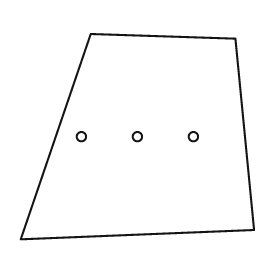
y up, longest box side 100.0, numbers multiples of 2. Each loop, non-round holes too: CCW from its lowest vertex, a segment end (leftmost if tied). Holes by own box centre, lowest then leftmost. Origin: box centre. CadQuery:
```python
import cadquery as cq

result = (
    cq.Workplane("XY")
    .moveTo(-50.0, -44.0)
    .lineTo(50.0, -40.0)
    .lineTo(42.0, 42.0)
    .lineTo(-20.0, 44.0)
    .close()
    .moveTo(-24.0, 0.0)
    .circle(2.0)
    .moveTo(0.0, 0.0)
    .circle(2.0)
    .moveTo(24.0, 0.0)
    .circle(2.0)
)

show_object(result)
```